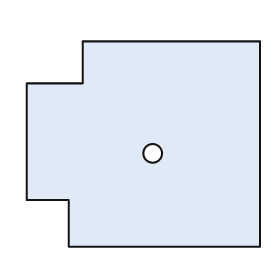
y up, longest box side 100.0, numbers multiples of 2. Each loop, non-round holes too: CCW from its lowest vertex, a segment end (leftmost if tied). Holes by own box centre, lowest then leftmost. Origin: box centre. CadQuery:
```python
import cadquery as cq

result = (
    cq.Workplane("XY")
    .moveTo(-32.0, -44.0)
    .lineTo(50.0, -44.0)
    .lineTo(50.0, 44.0)
    .lineTo(-26.0, 44.0)
    .lineTo(-26.0, 26.0)
    .lineTo(-50.0, 26.0)
    .lineTo(-50.0, -24.0)
    .lineTo(-32.0, -24.0)
    .close()
    .moveTo(4.0, -4.0)
    .circle(4.0)
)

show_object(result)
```